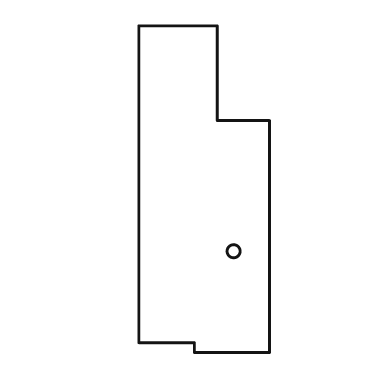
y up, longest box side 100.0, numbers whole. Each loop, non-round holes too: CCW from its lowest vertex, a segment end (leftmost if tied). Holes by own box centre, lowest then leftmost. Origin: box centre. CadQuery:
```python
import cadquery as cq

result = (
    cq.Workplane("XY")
    .moveTo(-3.0, -50.0)
    .lineTo(20.0, -50.0)
    .lineTo(20.0, 21.0)
    .lineTo(4.0, 21.0)
    .lineTo(4.0, 50.0)
    .lineTo(-20.0, 50.0)
    .lineTo(-20.0, -47.0)
    .lineTo(-3.0, -47.0)
    .close()
    .moveTo(9.0, -19.0)
    .circle(2.0)
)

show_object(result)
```